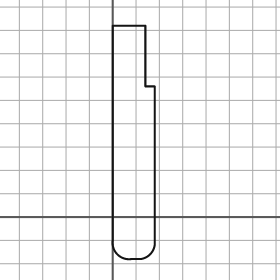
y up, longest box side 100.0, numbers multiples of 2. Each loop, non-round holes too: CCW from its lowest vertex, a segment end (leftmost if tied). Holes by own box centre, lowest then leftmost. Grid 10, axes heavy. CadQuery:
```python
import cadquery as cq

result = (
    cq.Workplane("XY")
    .moveTo(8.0, -18.0)
    .lineTo(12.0, -18.0)
    .threePointArc((16.0, -16.0), (18.0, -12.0))
    .lineTo(18.0, 56.0)
    .lineTo(14.0, 56.0)
    .lineTo(14.0, 82.0)
    .lineTo(0.0, 82.0)
    .lineTo(0.0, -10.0)
    .threePointArc((2.0, -16.0), (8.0, -18.0))
    .close()
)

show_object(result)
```